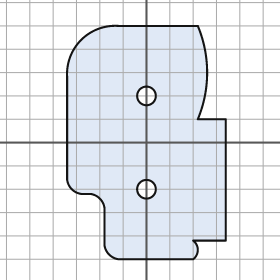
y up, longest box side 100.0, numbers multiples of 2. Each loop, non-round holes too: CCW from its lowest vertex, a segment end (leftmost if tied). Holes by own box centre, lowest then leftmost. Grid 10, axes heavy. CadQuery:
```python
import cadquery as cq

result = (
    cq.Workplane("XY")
    .moveTo(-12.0, -50.0)
    .lineTo(20.0, -50.0)
    .threePointArc((22.0, -46.0), (20.0, -42.0))
    .lineTo(34.0, -42.0)
    .lineTo(34.0, 10.0)
    .lineTo(22.0, 10.0)
    .threePointArc((26.0, 30.0), (22.0, 50.0))
    .lineTo(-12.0, 50.0)
    .threePointArc((-28.0, 44.0), (-34.0, 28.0))
    .lineTo(-34.0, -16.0)
    .threePointArc((-32.0, -20.0), (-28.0, -22.0))
    .lineTo(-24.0, -22.0)
    .threePointArc((-20.0, -24.0), (-18.0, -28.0))
    .lineTo(-18.0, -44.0)
    .threePointArc((-16.0, -48.0), (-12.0, -50.0))
    .close()
    .moveTo(0.0, -20.0)
    .circle(4.0)
    .moveTo(0.0, 20.0)
    .circle(4.0)
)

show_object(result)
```